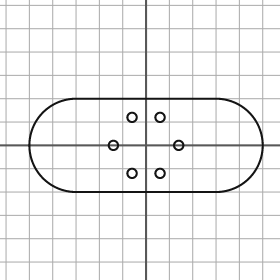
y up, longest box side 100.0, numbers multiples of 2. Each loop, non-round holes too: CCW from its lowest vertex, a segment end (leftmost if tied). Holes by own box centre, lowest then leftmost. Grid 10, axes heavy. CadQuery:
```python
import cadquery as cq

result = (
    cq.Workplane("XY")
    .moveTo(-30.0, -20.0)
    .lineTo(30.0, -20.0)
    .threePointArc((50.0, 0.0), (30.0, 20.0))
    .lineTo(-30.0, 20.0)
    .threePointArc((-50.0, 0.0), (-30.0, -20.0))
    .close()
    .moveTo(-6.0, -12.0)
    .circle(2.0)
    .moveTo(6.0, -12.0)
    .circle(2.0)
    .moveTo(-14.0, 0.0)
    .circle(2.0)
    .moveTo(14.0, 0.0)
    .circle(2.0)
    .moveTo(-6.0, 12.0)
    .circle(2.0)
    .moveTo(6.0, 12.0)
    .circle(2.0)
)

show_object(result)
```